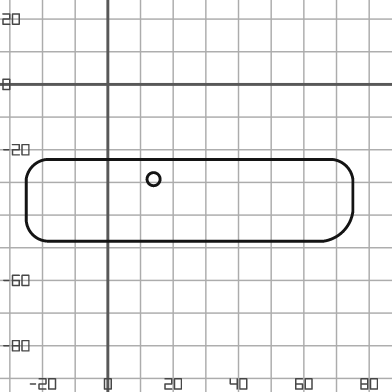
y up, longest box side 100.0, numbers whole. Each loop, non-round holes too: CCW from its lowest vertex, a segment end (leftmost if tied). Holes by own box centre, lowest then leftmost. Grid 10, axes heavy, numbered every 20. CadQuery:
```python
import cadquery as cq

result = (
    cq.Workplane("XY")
    .moveTo(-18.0, -48.0)
    .lineTo(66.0, -48.0)
    .threePointArc((72.0, -45.0), (75.0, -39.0))
    .lineTo(75.0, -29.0)
    .threePointArc((73.0, -25.0), (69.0, -23.0))
    .lineTo(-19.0, -23.0)
    .threePointArc((-23.0, -25.0), (-25.0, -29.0))
    .lineTo(-25.0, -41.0)
    .threePointArc((-23.0, -46.0), (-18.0, -48.0))
    .close()
    .moveTo(14.0, -29.0)
    .circle(2.0)
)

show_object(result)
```